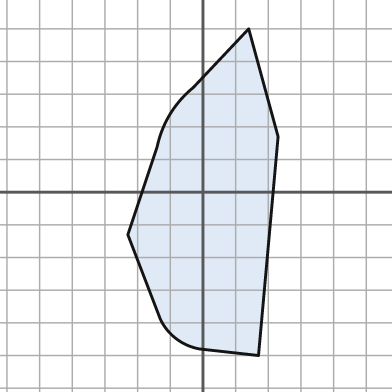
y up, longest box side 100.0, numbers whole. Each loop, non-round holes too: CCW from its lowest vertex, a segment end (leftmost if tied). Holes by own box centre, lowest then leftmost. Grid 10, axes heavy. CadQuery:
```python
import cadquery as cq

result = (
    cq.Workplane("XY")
    .moveTo(17.0, -50.0)
    .lineTo(23.0, 17.0)
    .lineTo(14.0, 50.0)
    .lineTo(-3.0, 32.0)
    .threePointArc((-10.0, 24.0), (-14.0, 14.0))
    .lineTo(-23.0, -13.0)
    .lineTo(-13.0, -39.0)
    .threePointArc((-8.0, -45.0), (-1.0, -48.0))
    .close()
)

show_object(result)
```